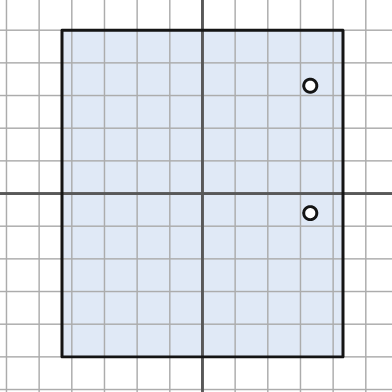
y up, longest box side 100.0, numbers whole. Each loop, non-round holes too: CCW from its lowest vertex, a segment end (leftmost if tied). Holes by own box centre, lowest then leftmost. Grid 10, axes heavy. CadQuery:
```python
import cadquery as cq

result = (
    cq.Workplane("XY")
    .moveTo(-43.0, -50.0)
    .lineTo(43.0, -50.0)
    .lineTo(43.0, 50.0)
    .lineTo(-43.0, 50.0)
    .close()
    .moveTo(33.0, -6.0)
    .circle(2.0)
    .moveTo(33.0, 33.0)
    .circle(2.0)
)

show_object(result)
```